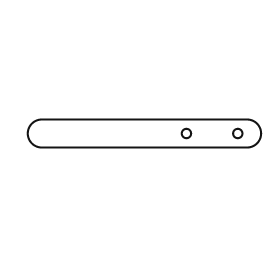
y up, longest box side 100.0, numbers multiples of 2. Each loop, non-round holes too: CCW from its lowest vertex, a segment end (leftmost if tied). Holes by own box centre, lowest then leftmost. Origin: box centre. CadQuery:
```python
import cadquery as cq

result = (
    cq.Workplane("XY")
    .moveTo(-44.0, -6.0)
    .lineTo(44.0, -6.0)
    .threePointArc((50.0, 0.0), (44.0, 6.0))
    .lineTo(-44.0, 6.0)
    .threePointArc((-50.0, 0.0), (-44.0, -6.0))
    .close()
    .moveTo(18.0, 0.0)
    .circle(2.0)
    .moveTo(40.0, 0.0)
    .circle(2.0)
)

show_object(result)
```